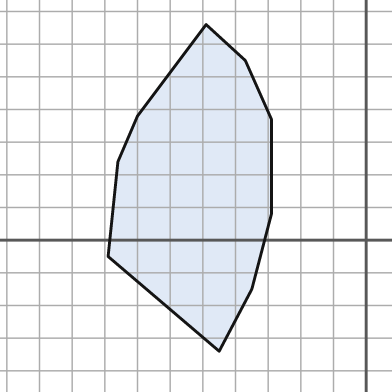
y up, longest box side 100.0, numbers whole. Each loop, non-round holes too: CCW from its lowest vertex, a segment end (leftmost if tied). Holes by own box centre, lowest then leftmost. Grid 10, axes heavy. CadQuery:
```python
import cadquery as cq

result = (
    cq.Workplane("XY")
    .moveTo(-45.0, -34.0)
    .lineTo(-35.0, -15.0)
    .lineTo(-29.0, 8.0)
    .lineTo(-29.0, 37.0)
    .lineTo(-37.0, 55.0)
    .lineTo(-49.0, 66.0)
    .lineTo(-70.0, 38.0)
    .lineTo(-76.0, 24.0)
    .lineTo(-79.0, -5.0)
    .close()
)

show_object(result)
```